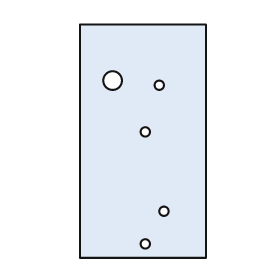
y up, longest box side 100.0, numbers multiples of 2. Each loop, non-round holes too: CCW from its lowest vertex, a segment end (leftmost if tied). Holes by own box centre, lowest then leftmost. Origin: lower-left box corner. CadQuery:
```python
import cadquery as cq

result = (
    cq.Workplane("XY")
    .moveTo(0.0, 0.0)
    .lineTo(54.0, 0.0)
    .lineTo(54.0, 100.0)
    .lineTo(0.0, 100.0)
    .close()
    .moveTo(28.0, 6.0)
    .circle(2.0)
    .moveTo(36.0, 20.0)
    .circle(2.0)
    .moveTo(28.0, 54.0)
    .circle(2.0)
    .moveTo(34.0, 74.0)
    .circle(2.0)
    .moveTo(14.0, 76.0)
    .circle(4.0)
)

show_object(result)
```